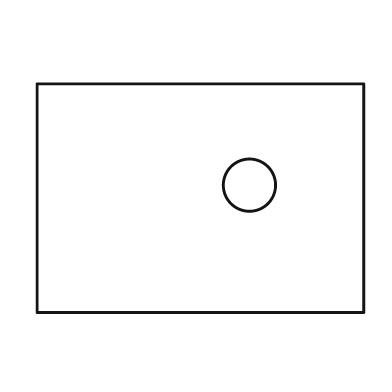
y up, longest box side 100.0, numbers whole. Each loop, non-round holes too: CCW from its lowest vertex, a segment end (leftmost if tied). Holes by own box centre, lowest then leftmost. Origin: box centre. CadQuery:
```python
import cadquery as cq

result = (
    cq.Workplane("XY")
    .moveTo(-50.0, -35.0)
    .lineTo(50.0, -35.0)
    .lineTo(50.0, 35.0)
    .lineTo(-50.0, 35.0)
    .close()
    .moveTo(15.0, 4.0)
    .circle(8.0)
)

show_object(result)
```